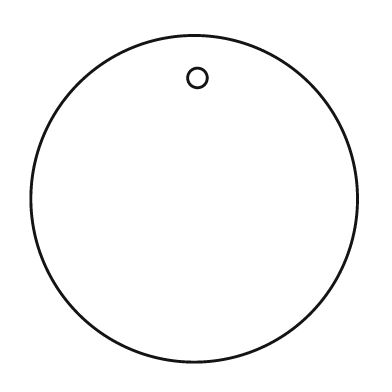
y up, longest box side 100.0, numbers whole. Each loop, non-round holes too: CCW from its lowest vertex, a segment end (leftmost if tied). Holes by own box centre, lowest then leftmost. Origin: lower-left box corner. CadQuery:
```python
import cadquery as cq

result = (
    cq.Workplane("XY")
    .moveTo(50.0, 50.0)
    .circle(50.0)
    .moveTo(51.0, 87.0)
    .circle(3.0)
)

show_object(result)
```